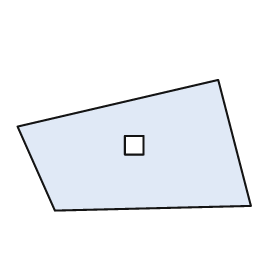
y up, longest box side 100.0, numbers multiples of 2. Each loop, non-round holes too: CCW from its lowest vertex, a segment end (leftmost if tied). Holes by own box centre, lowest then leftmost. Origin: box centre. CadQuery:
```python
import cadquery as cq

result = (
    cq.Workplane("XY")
    .moveTo(-34.0, -28.0)
    .lineTo(50.0, -26.0)
    .lineTo(36.0, 28.0)
    .lineTo(-50.0, 8.0)
    .close()
    .moveTo(-4.0, -4.0)
    .lineTo(4.0, -4.0)
    .lineTo(4.0, 4.0)
    .lineTo(-4.0, 4.0)
    .close()
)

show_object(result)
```